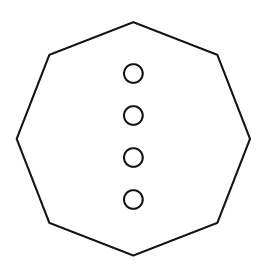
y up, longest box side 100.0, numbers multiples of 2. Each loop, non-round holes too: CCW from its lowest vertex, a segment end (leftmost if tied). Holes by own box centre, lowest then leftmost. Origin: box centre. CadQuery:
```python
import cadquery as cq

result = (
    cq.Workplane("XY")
    .moveTo(0.0, -50.0)
    .lineTo(36.0, -36.0)
    .lineTo(50.0, 0.0)
    .lineTo(36.0, 36.0)
    .lineTo(0.0, 50.0)
    .lineTo(-36.0, 36.0)
    .lineTo(-50.0, 0.0)
    .lineTo(-36.0, -36.0)
    .close()
    .moveTo(0.0, -26.0)
    .circle(4.0)
    .moveTo(0.0, -8.0)
    .circle(4.0)
    .moveTo(0.0, 10.0)
    .circle(4.0)
    .moveTo(0.0, 28.0)
    .circle(4.0)
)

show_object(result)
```